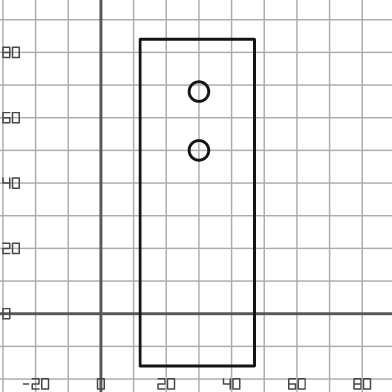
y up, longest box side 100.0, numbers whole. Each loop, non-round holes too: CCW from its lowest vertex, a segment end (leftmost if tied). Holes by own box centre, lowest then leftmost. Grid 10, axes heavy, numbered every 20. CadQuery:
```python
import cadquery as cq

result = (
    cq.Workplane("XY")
    .moveTo(12.0, -16.0)
    .lineTo(47.0, -16.0)
    .lineTo(47.0, 84.0)
    .lineTo(12.0, 84.0)
    .close()
    .moveTo(30.0, 50.0)
    .circle(3.0)
    .moveTo(30.0, 68.0)
    .circle(3.0)
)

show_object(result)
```